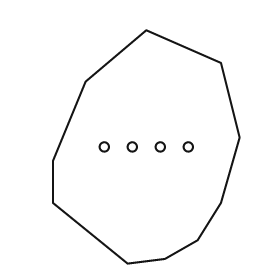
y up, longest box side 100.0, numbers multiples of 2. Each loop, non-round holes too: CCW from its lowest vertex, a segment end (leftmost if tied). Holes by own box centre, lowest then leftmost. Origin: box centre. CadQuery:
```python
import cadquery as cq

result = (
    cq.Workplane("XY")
    .moveTo(-8.0, -50.0)
    .lineTo(8.0, -48.0)
    .lineTo(22.0, -40.0)
    .lineTo(32.0, -24.0)
    .lineTo(40.0, 4.0)
    .lineTo(32.0, 36.0)
    .lineTo(0.0, 50.0)
    .lineTo(-26.0, 28.0)
    .lineTo(-40.0, -6.0)
    .lineTo(-40.0, -24.0)
    .close()
    .moveTo(-18.0, 0.0)
    .circle(2.0)
    .moveTo(-6.0, 0.0)
    .circle(2.0)
    .moveTo(6.0, 0.0)
    .circle(2.0)
    .moveTo(18.0, 0.0)
    .circle(2.0)
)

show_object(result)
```